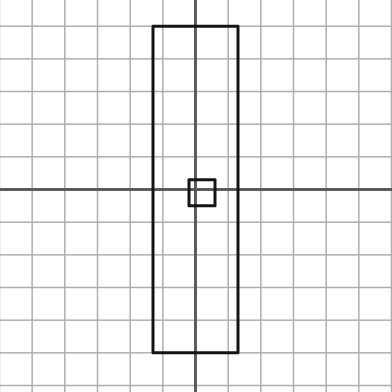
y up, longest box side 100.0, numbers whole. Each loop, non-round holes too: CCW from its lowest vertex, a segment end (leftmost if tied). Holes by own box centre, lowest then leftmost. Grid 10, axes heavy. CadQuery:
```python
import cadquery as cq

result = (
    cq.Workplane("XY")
    .moveTo(-13.0, -50.0)
    .lineTo(13.0, -50.0)
    .lineTo(13.0, 50.0)
    .lineTo(-13.0, 50.0)
    .close()
    .moveTo(-2.0, -5.0)
    .lineTo(6.0, -5.0)
    .lineTo(6.0, 3.0)
    .lineTo(-2.0, 3.0)
    .close()
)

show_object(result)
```